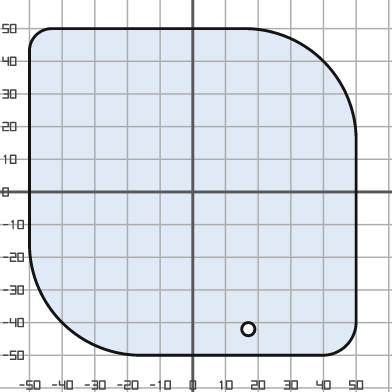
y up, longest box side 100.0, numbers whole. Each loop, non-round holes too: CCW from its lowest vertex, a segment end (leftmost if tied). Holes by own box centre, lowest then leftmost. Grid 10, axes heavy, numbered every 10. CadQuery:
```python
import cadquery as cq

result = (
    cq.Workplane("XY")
    .moveTo(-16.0, -50.0)
    .lineTo(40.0, -50.0)
    .threePointArc((47.0, -47.0), (50.0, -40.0))
    .lineTo(50.0, 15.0)
    .threePointArc((40.0, 40.0), (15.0, 50.0))
    .lineTo(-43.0, 50.0)
    .threePointArc((-48.0, 48.0), (-50.0, 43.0))
    .lineTo(-50.0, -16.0)
    .threePointArc((-40.0, -40.0), (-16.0, -50.0))
    .close()
    .moveTo(17.0, -42.0)
    .circle(2.0)
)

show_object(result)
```